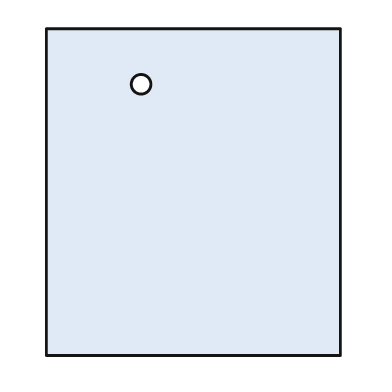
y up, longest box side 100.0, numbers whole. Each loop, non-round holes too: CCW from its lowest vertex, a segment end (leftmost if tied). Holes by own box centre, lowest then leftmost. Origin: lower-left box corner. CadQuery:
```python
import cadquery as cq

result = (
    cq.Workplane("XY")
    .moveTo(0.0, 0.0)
    .lineTo(90.0, 0.0)
    .lineTo(90.0, 100.0)
    .lineTo(0.0, 100.0)
    .close()
    .moveTo(29.0, 83.0)
    .circle(3.0)
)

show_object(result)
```